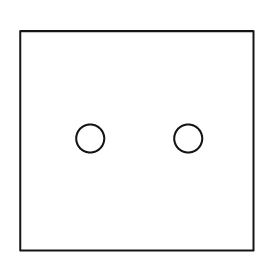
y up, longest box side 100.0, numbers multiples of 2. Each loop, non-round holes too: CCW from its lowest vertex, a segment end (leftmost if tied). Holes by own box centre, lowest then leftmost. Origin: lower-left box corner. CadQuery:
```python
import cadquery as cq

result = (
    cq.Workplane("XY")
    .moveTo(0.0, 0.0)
    .lineTo(100.0, 0.0)
    .lineTo(100.0, 94.0)
    .lineTo(0.0, 94.0)
    .close()
    .moveTo(30.0, 48.0)
    .circle(6.0)
    .moveTo(72.0, 48.0)
    .circle(6.0)
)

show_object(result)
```